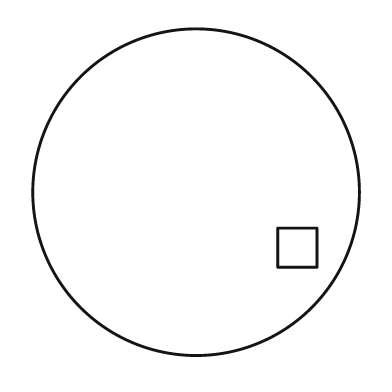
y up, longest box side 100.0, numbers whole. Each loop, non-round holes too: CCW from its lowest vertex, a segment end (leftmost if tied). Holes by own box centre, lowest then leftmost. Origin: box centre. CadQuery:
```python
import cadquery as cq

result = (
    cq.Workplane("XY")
    .moveTo(0.0, 0.0)
    .circle(50.0)
    .moveTo(25.0, -23.0)
    .lineTo(37.0, -23.0)
    .lineTo(37.0, -11.0)
    .lineTo(25.0, -11.0)
    .close()
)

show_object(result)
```